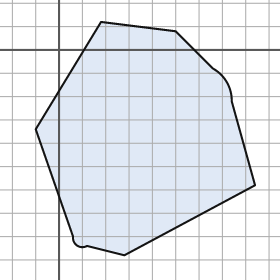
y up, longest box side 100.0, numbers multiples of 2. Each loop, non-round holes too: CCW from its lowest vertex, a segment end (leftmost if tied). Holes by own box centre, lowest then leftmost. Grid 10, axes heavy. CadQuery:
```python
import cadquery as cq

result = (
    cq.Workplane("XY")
    .moveTo(28.0, -88.0)
    .lineTo(84.0, -58.0)
    .lineTo(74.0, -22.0)
    .threePointArc((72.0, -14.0), (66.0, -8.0))
    .lineTo(50.0, 8.0)
    .lineTo(18.0, 12.0)
    .lineTo(-10.0, -34.0)
    .lineTo(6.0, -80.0)
    .threePointArc((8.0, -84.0), (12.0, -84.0))
    .close()
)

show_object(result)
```